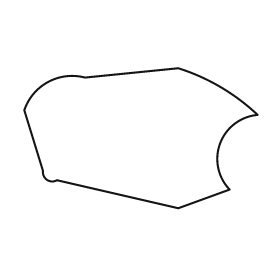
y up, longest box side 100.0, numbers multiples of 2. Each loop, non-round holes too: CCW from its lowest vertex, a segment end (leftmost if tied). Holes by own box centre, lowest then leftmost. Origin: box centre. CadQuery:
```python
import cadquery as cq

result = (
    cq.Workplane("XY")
    .moveTo(16.0, -30.0)
    .lineTo(38.0, -22.0)
    .threePointArc((34.0, -2.0), (50.0, 10.0))
    .threePointArc((34.0, 22.0), (16.0, 30.0))
    .lineTo(-24.0, 26.0)
    .threePointArc((-40.0, 24.0), (-50.0, 12.0))
    .lineTo(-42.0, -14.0)
    .threePointArc((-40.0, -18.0), (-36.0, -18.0))
    .close()
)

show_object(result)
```